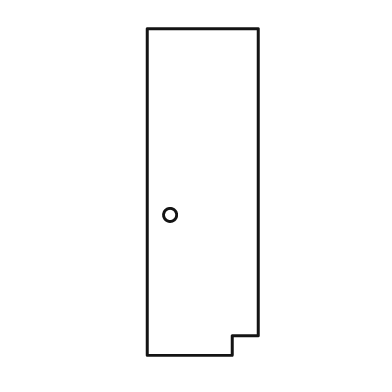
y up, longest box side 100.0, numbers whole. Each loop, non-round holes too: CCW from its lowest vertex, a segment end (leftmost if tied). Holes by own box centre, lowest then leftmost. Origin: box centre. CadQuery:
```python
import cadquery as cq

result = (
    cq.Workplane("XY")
    .moveTo(-17.0, -50.0)
    .lineTo(9.0, -50.0)
    .lineTo(9.0, -44.0)
    .lineTo(17.0, -44.0)
    .lineTo(17.0, 50.0)
    .lineTo(-17.0, 50.0)
    .close()
    .moveTo(-10.0, -7.0)
    .circle(2.0)
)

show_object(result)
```